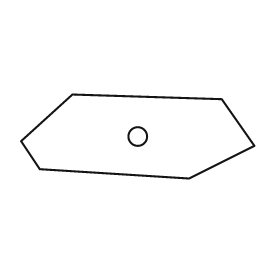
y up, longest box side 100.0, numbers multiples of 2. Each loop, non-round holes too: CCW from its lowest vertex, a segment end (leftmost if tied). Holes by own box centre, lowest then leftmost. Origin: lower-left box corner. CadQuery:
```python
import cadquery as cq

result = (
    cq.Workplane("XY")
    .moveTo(72.0, 0.0)
    .lineTo(100.0, 14.0)
    .lineTo(86.0, 34.0)
    .lineTo(22.0, 36.0)
    .lineTo(0.0, 16.0)
    .lineTo(8.0, 4.0)
    .close()
    .moveTo(50.0, 18.0)
    .circle(4.0)
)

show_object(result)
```